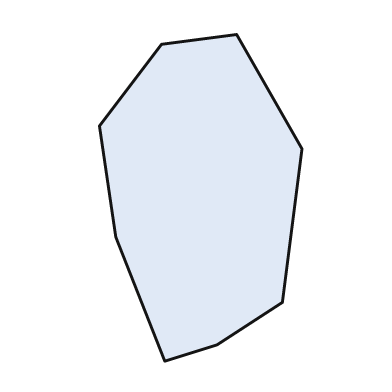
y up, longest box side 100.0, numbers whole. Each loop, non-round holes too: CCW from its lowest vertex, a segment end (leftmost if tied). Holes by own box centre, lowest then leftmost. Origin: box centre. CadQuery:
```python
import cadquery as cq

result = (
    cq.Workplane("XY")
    .moveTo(-11.0, -50.0)
    .lineTo(5.0, -45.0)
    .lineTo(25.0, -32.0)
    .lineTo(31.0, 15.0)
    .lineTo(11.0, 50.0)
    .lineTo(-12.0, 47.0)
    .lineTo(-31.0, 22.0)
    .lineTo(-26.0, -12.0)
    .close()
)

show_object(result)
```